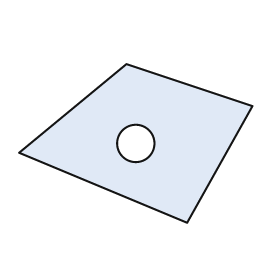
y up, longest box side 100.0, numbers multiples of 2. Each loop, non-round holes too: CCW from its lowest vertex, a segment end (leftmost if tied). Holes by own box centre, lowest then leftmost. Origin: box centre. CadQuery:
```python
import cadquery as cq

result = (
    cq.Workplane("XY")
    .moveTo(22.0, -34.0)
    .lineTo(50.0, 16.0)
    .lineTo(-4.0, 34.0)
    .lineTo(-50.0, -4.0)
    .close()
    .moveTo(0.0, 0.0)
    .circle(8.0)
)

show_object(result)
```